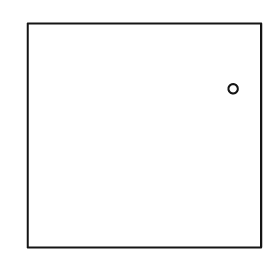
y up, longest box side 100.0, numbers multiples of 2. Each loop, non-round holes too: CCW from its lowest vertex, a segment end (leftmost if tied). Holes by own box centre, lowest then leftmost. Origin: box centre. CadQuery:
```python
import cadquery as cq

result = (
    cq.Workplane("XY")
    .moveTo(-50.0, -48.0)
    .lineTo(50.0, -48.0)
    .lineTo(50.0, 48.0)
    .lineTo(-50.0, 48.0)
    .close()
    .moveTo(38.0, 20.0)
    .circle(2.0)
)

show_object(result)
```